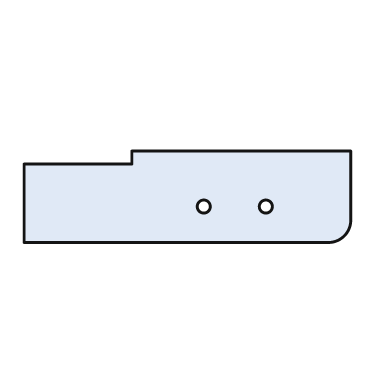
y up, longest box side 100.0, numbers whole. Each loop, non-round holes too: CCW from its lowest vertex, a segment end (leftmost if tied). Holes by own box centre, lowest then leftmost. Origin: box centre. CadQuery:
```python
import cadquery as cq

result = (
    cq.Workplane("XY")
    .moveTo(-50.0, -14.0)
    .lineTo(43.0, -14.0)
    .threePointArc((48.0, -12.0), (50.0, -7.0))
    .lineTo(50.0, 14.0)
    .lineTo(-17.0, 14.0)
    .lineTo(-17.0, 10.0)
    .lineTo(-50.0, 10.0)
    .close()
    .moveTo(5.0, -3.0)
    .circle(2.0)
    .moveTo(24.0, -3.0)
    .circle(2.0)
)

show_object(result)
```